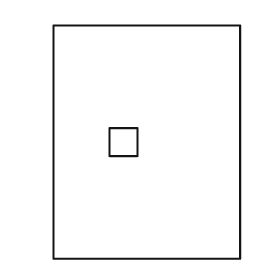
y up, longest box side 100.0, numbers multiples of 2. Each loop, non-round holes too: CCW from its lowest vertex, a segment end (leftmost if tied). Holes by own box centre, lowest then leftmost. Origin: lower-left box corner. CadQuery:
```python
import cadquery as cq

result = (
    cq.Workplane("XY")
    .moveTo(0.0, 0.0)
    .lineTo(80.0, 0.0)
    .lineTo(80.0, 100.0)
    .lineTo(0.0, 100.0)
    .close()
    .moveTo(24.0, 44.0)
    .lineTo(36.0, 44.0)
    .lineTo(36.0, 56.0)
    .lineTo(24.0, 56.0)
    .close()
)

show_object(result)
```